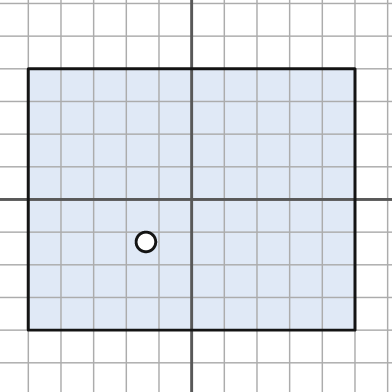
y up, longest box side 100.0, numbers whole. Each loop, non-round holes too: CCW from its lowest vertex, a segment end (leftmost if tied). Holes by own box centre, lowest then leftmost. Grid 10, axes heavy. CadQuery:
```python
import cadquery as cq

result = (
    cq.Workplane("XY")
    .moveTo(-50.0, -40.0)
    .lineTo(50.0, -40.0)
    .lineTo(50.0, 40.0)
    .lineTo(-50.0, 40.0)
    .close()
    .moveTo(-14.0, -13.0)
    .circle(3.0)
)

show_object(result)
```